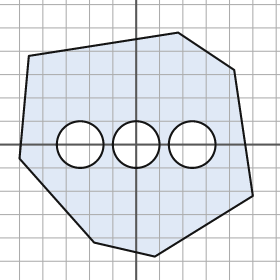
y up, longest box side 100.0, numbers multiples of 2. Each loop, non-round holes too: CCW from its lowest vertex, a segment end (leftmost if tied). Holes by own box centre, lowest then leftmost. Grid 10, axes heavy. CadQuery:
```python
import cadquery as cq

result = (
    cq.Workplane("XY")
    .moveTo(8.0, -48.0)
    .lineTo(50.0, -22.0)
    .lineTo(42.0, 32.0)
    .lineTo(18.0, 48.0)
    .lineTo(-46.0, 38.0)
    .lineTo(-50.0, -6.0)
    .lineTo(-18.0, -42.0)
    .close()
    .moveTo(-24.0, 0.0)
    .circle(10.0)
    .moveTo(0.0, 0.0)
    .circle(10.0)
    .moveTo(24.0, 0.0)
    .circle(10.0)
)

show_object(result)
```